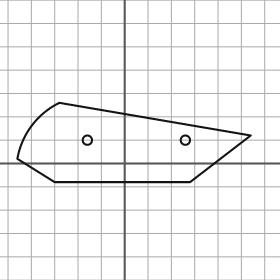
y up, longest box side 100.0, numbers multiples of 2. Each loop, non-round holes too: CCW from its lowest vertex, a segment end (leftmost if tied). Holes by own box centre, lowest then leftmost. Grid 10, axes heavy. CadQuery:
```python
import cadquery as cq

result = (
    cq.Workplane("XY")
    .moveTo(-30.0, -8.0)
    .lineTo(28.0, -8.0)
    .lineTo(54.0, 12.0)
    .lineTo(-28.0, 26.0)
    .threePointArc((-40.0, 16.0), (-46.0, 2.0))
    .close()
    .moveTo(-16.0, 10.0)
    .circle(2.0)
    .moveTo(26.0, 10.0)
    .circle(2.0)
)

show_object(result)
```